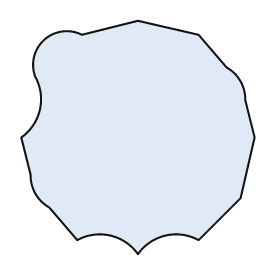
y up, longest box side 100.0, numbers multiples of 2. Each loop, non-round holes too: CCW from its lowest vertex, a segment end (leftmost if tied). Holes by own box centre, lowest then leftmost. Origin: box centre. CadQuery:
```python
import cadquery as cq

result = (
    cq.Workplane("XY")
    .moveTo(0.0, -50.0)
    .threePointArc((12.0, -42.0), (26.0, -44.0))
    .lineTo(44.0, -26.0)
    .lineTo(50.0, 0.0)
    .lineTo(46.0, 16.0)
    .threePointArc((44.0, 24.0), (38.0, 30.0))
    .lineTo(26.0, 44.0)
    .lineTo(0.0, 50.0)
    .lineTo(-24.0, 44.0)
    .threePointArc((-40.0, 42.0), (-44.0, 26.0))
    .threePointArc((-42.0, 12.0), (-50.0, 0.0))
    .lineTo(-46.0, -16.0)
    .threePointArc((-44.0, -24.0), (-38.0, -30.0))
    .lineTo(-26.0, -44.0)
    .threePointArc((-12.0, -42.0), (0.0, -50.0))
    .close()
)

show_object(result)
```